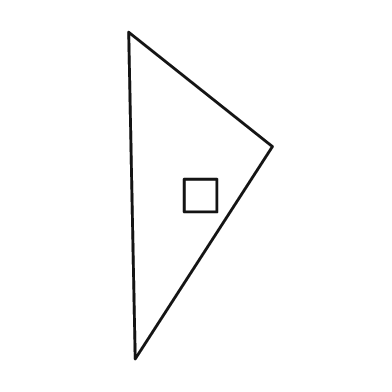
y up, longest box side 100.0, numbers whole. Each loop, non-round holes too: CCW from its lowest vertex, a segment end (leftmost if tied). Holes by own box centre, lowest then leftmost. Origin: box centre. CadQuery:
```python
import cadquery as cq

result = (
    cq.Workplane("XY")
    .moveTo(-20.0, -50.0)
    .lineTo(22.0, 15.0)
    .lineTo(-22.0, 50.0)
    .close()
    .moveTo(-5.0, -5.0)
    .lineTo(5.0, -5.0)
    .lineTo(5.0, 5.0)
    .lineTo(-5.0, 5.0)
    .close()
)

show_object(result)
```